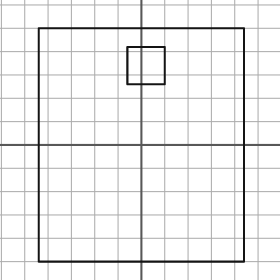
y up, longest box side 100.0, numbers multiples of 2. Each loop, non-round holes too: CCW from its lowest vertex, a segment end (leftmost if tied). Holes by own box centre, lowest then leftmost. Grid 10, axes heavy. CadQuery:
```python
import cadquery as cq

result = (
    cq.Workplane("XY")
    .moveTo(-44.0, -50.0)
    .lineTo(44.0, -50.0)
    .lineTo(44.0, 50.0)
    .lineTo(-44.0, 50.0)
    .close()
    .moveTo(-6.0, 26.0)
    .lineTo(10.0, 26.0)
    .lineTo(10.0, 42.0)
    .lineTo(-6.0, 42.0)
    .close()
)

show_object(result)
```